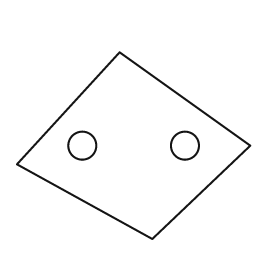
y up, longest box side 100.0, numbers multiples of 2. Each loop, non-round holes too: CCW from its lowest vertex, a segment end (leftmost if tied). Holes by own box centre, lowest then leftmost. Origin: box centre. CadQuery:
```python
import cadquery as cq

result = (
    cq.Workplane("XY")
    .moveTo(8.0, -40.0)
    .lineTo(50.0, 0.0)
    .lineTo(-6.0, 40.0)
    .lineTo(-50.0, -8.0)
    .close()
    .moveTo(-22.0, 0.0)
    .circle(6.0)
    .moveTo(22.0, 0.0)
    .circle(6.0)
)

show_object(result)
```